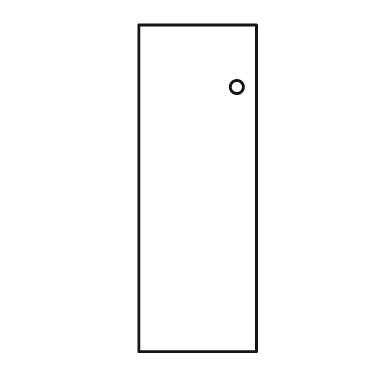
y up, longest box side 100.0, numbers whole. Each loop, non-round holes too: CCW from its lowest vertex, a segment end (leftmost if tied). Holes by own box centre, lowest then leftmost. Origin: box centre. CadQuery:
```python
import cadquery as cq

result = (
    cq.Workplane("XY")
    .moveTo(-18.0, -50.0)
    .lineTo(18.0, -50.0)
    .lineTo(18.0, 50.0)
    .lineTo(-18.0, 50.0)
    .close()
    .moveTo(12.0, 31.0)
    .circle(2.0)
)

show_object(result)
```